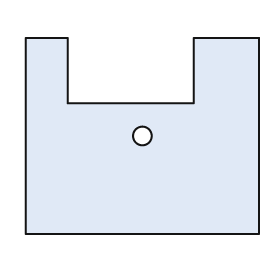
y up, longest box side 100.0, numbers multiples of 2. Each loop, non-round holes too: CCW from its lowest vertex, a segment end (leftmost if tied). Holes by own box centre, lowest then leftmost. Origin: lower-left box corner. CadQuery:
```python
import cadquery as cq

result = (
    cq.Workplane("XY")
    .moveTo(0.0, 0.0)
    .lineTo(100.0, 0.0)
    .lineTo(100.0, 84.0)
    .lineTo(72.0, 84.0)
    .lineTo(72.0, 56.0)
    .lineTo(18.0, 56.0)
    .lineTo(18.0, 84.0)
    .lineTo(0.0, 84.0)
    .close()
    .moveTo(50.0, 42.0)
    .circle(4.0)
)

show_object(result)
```